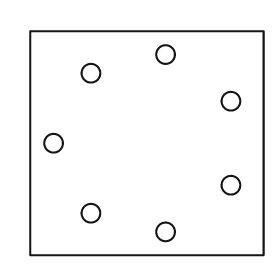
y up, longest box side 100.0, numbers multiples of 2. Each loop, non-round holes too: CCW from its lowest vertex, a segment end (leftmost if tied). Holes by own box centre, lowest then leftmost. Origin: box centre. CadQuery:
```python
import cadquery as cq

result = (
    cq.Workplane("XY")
    .moveTo(-50.0, -48.0)
    .lineTo(50.0, -48.0)
    .lineTo(50.0, 48.0)
    .lineTo(-50.0, 48.0)
    .close()
    .moveTo(8.0, -38.0)
    .circle(4.0)
    .moveTo(-24.0, -30.0)
    .circle(4.0)
    .moveTo(36.0, -18.0)
    .circle(4.0)
    .moveTo(-40.0, 0.0)
    .circle(4.0)
    .moveTo(36.0, 18.0)
    .circle(4.0)
    .moveTo(-24.0, 30.0)
    .circle(4.0)
    .moveTo(8.0, 38.0)
    .circle(4.0)
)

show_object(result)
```